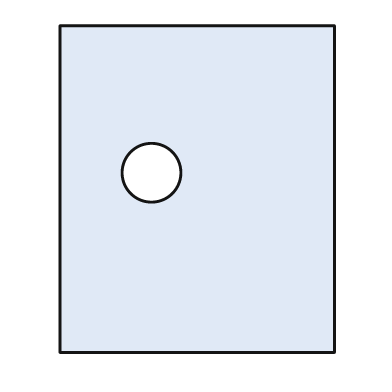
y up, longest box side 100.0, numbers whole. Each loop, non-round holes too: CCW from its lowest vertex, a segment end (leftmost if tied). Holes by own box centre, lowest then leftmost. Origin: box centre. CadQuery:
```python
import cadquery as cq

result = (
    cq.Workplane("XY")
    .moveTo(-42.0, -50.0)
    .lineTo(42.0, -50.0)
    .lineTo(42.0, 50.0)
    .lineTo(-42.0, 50.0)
    .close()
    .moveTo(-14.0, 5.0)
    .circle(9.0)
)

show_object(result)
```